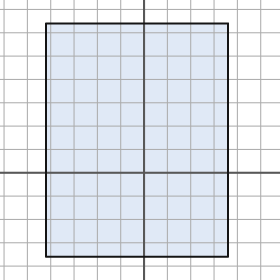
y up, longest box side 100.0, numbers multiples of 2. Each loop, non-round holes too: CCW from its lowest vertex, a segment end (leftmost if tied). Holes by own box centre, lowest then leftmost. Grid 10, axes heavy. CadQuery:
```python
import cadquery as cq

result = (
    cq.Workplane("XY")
    .moveTo(-42.0, -36.0)
    .lineTo(36.0, -36.0)
    .lineTo(36.0, 64.0)
    .lineTo(-42.0, 64.0)
    .close()
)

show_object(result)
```